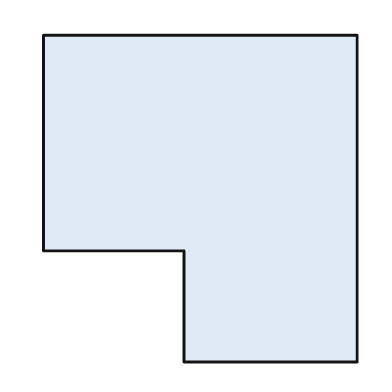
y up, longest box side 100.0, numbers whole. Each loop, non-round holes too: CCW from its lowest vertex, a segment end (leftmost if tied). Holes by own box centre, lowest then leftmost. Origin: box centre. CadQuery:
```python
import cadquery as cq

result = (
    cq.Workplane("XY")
    .moveTo(-5.0, -50.0)
    .lineTo(48.0, -50.0)
    .lineTo(48.0, 50.0)
    .lineTo(-48.0, 50.0)
    .lineTo(-48.0, -16.0)
    .lineTo(-5.0, -16.0)
    .close()
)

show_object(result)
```